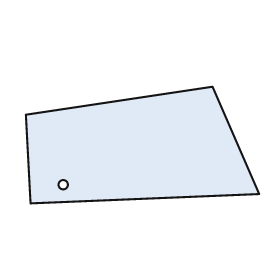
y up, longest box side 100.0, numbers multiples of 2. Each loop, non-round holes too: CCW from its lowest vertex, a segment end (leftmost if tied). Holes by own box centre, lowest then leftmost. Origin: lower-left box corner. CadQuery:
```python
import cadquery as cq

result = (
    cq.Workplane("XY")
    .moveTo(2.0, 0.0)
    .lineTo(100.0, 4.0)
    .lineTo(80.0, 50.0)
    .lineTo(0.0, 38.0)
    .close()
    .moveTo(16.0, 8.0)
    .circle(2.0)
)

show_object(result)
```